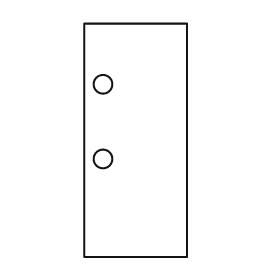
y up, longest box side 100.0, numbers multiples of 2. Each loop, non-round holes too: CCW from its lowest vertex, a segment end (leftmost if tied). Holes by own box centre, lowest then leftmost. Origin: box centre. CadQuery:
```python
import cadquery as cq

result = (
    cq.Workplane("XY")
    .moveTo(-22.0, -50.0)
    .lineTo(22.0, -50.0)
    .lineTo(22.0, 50.0)
    .lineTo(-22.0, 50.0)
    .close()
    .moveTo(-14.0, -8.0)
    .circle(4.0)
    .moveTo(-14.0, 24.0)
    .circle(4.0)
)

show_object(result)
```